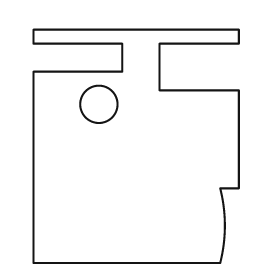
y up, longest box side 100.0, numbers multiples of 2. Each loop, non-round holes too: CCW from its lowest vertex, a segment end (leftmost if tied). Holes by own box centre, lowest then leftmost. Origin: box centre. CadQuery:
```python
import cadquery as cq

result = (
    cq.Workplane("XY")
    .moveTo(-44.0, -50.0)
    .lineTo(36.0, -50.0)
    .threePointArc((38.0, -34.0), (36.0, -18.0))
    .lineTo(44.0, -18.0)
    .lineTo(44.0, 24.0)
    .lineTo(10.0, 24.0)
    .lineTo(10.0, 44.0)
    .lineTo(44.0, 44.0)
    .lineTo(44.0, 50.0)
    .lineTo(-44.0, 50.0)
    .lineTo(-44.0, 44.0)
    .lineTo(-6.0, 44.0)
    .lineTo(-6.0, 32.0)
    .lineTo(-44.0, 32.0)
    .close()
    .moveTo(-16.0, 18.0)
    .circle(8.0)
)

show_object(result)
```